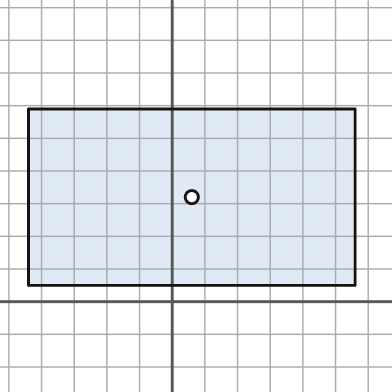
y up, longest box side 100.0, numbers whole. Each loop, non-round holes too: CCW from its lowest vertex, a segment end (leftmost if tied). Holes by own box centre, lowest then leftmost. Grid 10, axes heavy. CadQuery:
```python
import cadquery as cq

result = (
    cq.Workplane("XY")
    .moveTo(-44.0, 5.0)
    .lineTo(56.0, 5.0)
    .lineTo(56.0, 59.0)
    .lineTo(-44.0, 59.0)
    .close()
    .moveTo(6.0, 32.0)
    .circle(2.0)
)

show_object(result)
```